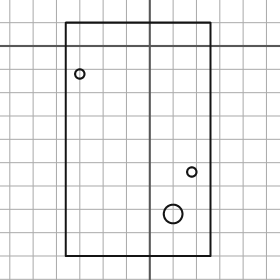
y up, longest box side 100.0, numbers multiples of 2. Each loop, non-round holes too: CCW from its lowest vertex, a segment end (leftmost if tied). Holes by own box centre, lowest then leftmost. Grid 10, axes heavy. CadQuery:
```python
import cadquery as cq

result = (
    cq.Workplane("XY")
    .moveTo(-36.0, -90.0)
    .lineTo(26.0, -90.0)
    .lineTo(26.0, 10.0)
    .lineTo(-36.0, 10.0)
    .close()
    .moveTo(10.0, -72.0)
    .circle(4.0)
    .moveTo(18.0, -54.0)
    .circle(2.0)
    .moveTo(-30.0, -12.0)
    .circle(2.0)
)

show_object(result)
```